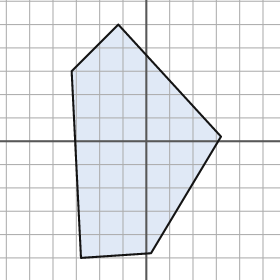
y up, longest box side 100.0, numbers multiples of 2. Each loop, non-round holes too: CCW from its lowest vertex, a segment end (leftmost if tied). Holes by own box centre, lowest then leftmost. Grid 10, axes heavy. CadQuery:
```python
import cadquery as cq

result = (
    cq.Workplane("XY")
    .moveTo(-28.0, -50.0)
    .lineTo(2.0, -48.0)
    .lineTo(32.0, 2.0)
    .lineTo(-12.0, 50.0)
    .lineTo(-32.0, 30.0)
    .close()
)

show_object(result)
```